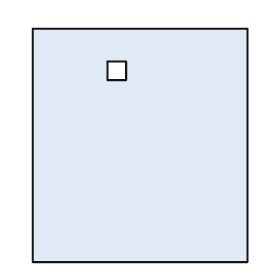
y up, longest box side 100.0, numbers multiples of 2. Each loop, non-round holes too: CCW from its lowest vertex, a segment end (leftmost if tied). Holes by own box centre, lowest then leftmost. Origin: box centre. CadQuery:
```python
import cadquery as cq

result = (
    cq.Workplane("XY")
    .moveTo(-46.0, -50.0)
    .lineTo(46.0, -50.0)
    .lineTo(46.0, 50.0)
    .lineTo(-46.0, 50.0)
    .close()
    .moveTo(-14.0, 28.0)
    .lineTo(-6.0, 28.0)
    .lineTo(-6.0, 36.0)
    .lineTo(-14.0, 36.0)
    .close()
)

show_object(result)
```